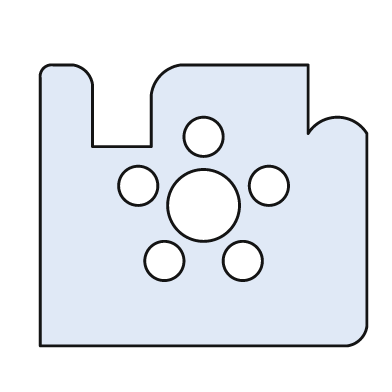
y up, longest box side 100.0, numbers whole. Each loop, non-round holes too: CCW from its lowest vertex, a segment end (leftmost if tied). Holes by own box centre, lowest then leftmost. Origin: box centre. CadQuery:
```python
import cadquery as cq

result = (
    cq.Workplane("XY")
    .moveTo(-50.0, -43.0)
    .lineTo(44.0, -43.0)
    .threePointArc((48.0, -41.0), (50.0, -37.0))
    .lineTo(50.0, 22.0)
    .threePointArc((41.0, 27.0), (32.0, 22.0))
    .lineTo(32.0, 43.0)
    .lineTo(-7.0, 43.0)
    .threePointArc((-13.0, 40.0), (-16.0, 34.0))
    .lineTo(-16.0, 18.0)
    .lineTo(-34.0, 18.0)
    .lineTo(-34.0, 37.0)
    .threePointArc((-36.0, 41.0), (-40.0, 43.0))
    .lineTo(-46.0, 43.0)
    .threePointArc((-49.0, 42.0), (-50.0, 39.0))
    .close()
    .moveTo(-12.0, -17.0)
    .circle(6.0)
    .moveTo(12.0, -17.0)
    .circle(6.0)
    .moveTo(0.0, 0.0)
    .circle(11.0)
    .moveTo(-20.0, 6.0)
    .circle(6.0)
    .moveTo(20.0, 6.0)
    .circle(6.0)
    .moveTo(0.0, 21.0)
    .circle(6.0)
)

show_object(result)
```